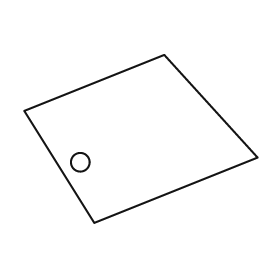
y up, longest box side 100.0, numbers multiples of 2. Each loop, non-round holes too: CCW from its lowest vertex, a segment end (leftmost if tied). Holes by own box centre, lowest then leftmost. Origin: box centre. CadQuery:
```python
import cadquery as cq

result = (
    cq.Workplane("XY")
    .moveTo(-20.0, -36.0)
    .lineTo(50.0, -8.0)
    .lineTo(10.0, 36.0)
    .lineTo(-50.0, 12.0)
    .close()
    .moveTo(-26.0, -10.0)
    .circle(4.0)
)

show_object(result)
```